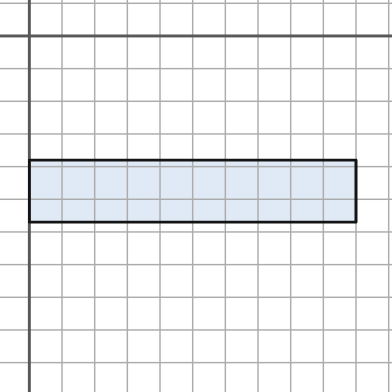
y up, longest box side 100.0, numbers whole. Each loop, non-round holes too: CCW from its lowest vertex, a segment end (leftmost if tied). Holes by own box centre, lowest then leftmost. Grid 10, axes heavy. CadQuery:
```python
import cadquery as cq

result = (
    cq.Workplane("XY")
    .moveTo(0.0, -57.0)
    .lineTo(100.0, -57.0)
    .lineTo(100.0, -38.0)
    .lineTo(0.0, -38.0)
    .close()
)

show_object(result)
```